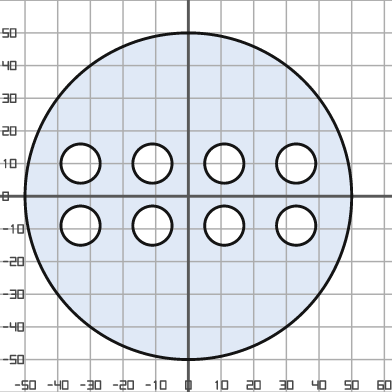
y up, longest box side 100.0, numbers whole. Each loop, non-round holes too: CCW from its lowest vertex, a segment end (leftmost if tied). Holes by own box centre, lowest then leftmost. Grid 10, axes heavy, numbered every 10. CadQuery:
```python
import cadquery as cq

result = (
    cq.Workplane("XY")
    .moveTo(0.0, 0.0)
    .circle(50.0)
    .moveTo(-33.0, -9.0)
    .circle(6.0)
    .moveTo(-11.0, -9.0)
    .circle(6.0)
    .moveTo(11.0, -9.0)
    .circle(6.0)
    .moveTo(33.0, -9.0)
    .circle(6.0)
    .moveTo(-33.0, 10.0)
    .circle(6.0)
    .moveTo(-11.0, 10.0)
    .circle(6.0)
    .moveTo(11.0, 10.0)
    .circle(6.0)
    .moveTo(33.0, 10.0)
    .circle(6.0)
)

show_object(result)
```